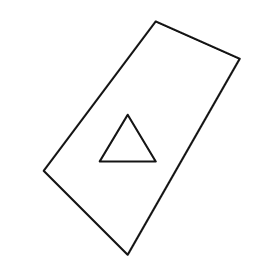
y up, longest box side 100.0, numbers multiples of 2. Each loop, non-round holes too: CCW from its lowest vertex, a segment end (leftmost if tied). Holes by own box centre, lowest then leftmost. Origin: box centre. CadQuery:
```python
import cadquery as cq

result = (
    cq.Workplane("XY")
    .moveTo(-6.0, -50.0)
    .lineTo(42.0, 34.0)
    .lineTo(6.0, 50.0)
    .lineTo(-42.0, -14.0)
    .close()
    .moveTo(-18.0, -10.0)
    .lineTo(6.0, -10.0)
    .lineTo(-6.0, 10.0)
    .close()
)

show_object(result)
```